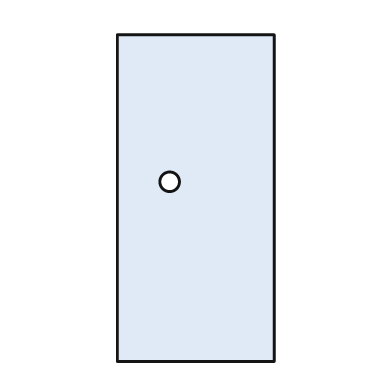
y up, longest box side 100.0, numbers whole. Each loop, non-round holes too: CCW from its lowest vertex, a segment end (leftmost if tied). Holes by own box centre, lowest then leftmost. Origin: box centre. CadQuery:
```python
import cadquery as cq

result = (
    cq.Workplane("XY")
    .moveTo(-24.0, -50.0)
    .lineTo(24.0, -50.0)
    .lineTo(24.0, 50.0)
    .lineTo(-24.0, 50.0)
    .close()
    .moveTo(-8.0, 5.0)
    .circle(3.0)
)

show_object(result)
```